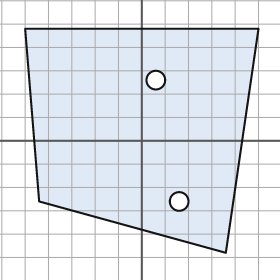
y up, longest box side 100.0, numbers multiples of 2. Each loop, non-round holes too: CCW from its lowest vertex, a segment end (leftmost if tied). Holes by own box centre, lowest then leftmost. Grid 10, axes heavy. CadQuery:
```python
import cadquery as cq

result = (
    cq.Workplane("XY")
    .moveTo(36.0, -48.0)
    .lineTo(50.0, 48.0)
    .lineTo(-50.0, 48.0)
    .lineTo(-44.0, -26.0)
    .close()
    .moveTo(16.0, -26.0)
    .circle(4.0)
    .moveTo(6.0, 26.0)
    .circle(4.0)
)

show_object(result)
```